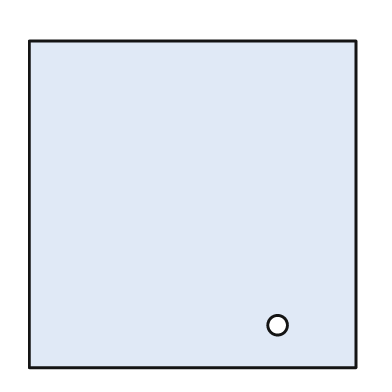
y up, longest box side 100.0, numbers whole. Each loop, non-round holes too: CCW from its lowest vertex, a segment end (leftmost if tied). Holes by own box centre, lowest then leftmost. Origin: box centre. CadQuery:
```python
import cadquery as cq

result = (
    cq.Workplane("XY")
    .moveTo(-50.0, -50.0)
    .lineTo(50.0, -50.0)
    .lineTo(50.0, 50.0)
    .lineTo(-50.0, 50.0)
    .close()
    .moveTo(26.0, -37.0)
    .circle(3.0)
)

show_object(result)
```